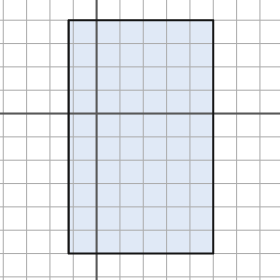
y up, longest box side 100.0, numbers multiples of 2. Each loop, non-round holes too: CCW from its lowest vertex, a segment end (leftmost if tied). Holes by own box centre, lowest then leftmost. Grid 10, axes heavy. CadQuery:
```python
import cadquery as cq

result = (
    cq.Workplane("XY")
    .moveTo(-12.0, -60.0)
    .lineTo(50.0, -60.0)
    .lineTo(50.0, 40.0)
    .lineTo(-12.0, 40.0)
    .close()
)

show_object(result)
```